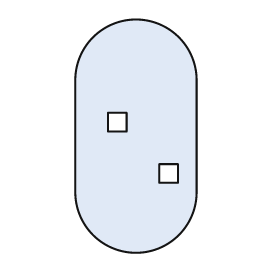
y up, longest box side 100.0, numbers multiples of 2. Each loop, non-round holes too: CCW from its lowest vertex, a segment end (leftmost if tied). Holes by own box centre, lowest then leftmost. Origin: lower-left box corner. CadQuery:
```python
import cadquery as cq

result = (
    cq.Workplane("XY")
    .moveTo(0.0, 26.0)
    .threePointArc((26.0, 0.0), (52.0, 26.0))
    .lineTo(52.0, 74.0)
    .threePointArc((26.0, 100.0), (0.0, 74.0))
    .close()
    .moveTo(36.0, 30.0)
    .lineTo(44.0, 30.0)
    .lineTo(44.0, 38.0)
    .lineTo(36.0, 38.0)
    .close()
    .moveTo(14.0, 52.0)
    .lineTo(22.0, 52.0)
    .lineTo(22.0, 60.0)
    .lineTo(14.0, 60.0)
    .close()
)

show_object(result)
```